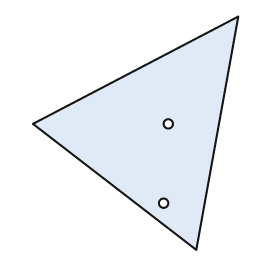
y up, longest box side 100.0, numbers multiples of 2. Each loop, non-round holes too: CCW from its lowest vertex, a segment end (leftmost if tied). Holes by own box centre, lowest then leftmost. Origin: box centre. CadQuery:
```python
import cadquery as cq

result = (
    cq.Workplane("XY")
    .moveTo(26.0, -50.0)
    .lineTo(44.0, 50.0)
    .lineTo(-44.0, 4.0)
    .close()
    .moveTo(12.0, -30.0)
    .circle(2.0)
    .moveTo(14.0, 4.0)
    .circle(2.0)
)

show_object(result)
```